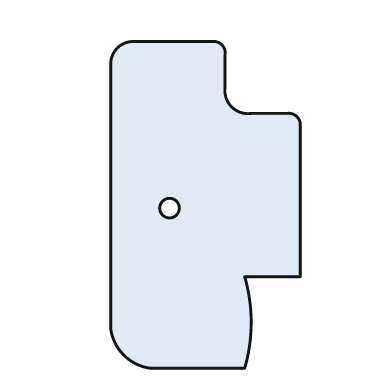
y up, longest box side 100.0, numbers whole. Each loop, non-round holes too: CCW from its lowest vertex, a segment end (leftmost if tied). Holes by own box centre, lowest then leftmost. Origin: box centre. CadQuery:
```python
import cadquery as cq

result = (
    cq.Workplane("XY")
    .moveTo(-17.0, -50.0)
    .lineTo(12.0, -50.0)
    .threePointArc((14.0, -36.0), (12.0, -22.0))
    .lineTo(29.0, -22.0)
    .lineTo(29.0, 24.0)
    .threePointArc((28.0, 27.0), (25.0, 28.0))
    .lineTo(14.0, 28.0)
    .threePointArc((8.0, 30.0), (6.0, 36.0))
    .lineTo(6.0, 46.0)
    .threePointArc((5.0, 49.0), (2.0, 50.0))
    .lineTo(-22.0, 50.0)
    .threePointArc((-27.0, 48.0), (-29.0, 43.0))
    .lineTo(-29.0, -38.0)
    .threePointArc((-25.0, -46.0), (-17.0, -50.0))
    .close()
    .moveTo(-11.0, -1.0)
    .circle(3.0)
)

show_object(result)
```